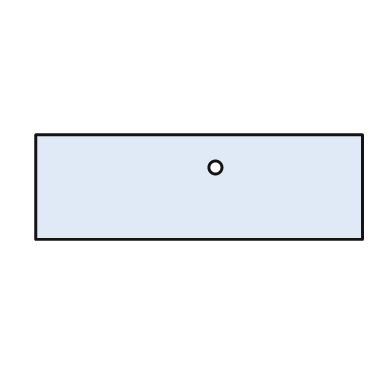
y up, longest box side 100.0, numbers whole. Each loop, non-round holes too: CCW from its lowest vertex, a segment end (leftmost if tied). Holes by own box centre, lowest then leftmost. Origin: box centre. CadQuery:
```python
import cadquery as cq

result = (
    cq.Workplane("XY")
    .moveTo(-50.0, -16.0)
    .lineTo(50.0, -16.0)
    .lineTo(50.0, 16.0)
    .lineTo(-50.0, 16.0)
    .close()
    .moveTo(5.0, 6.0)
    .circle(2.0)
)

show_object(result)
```